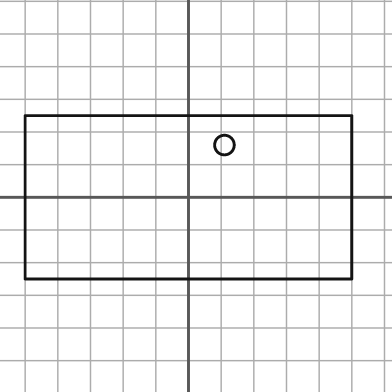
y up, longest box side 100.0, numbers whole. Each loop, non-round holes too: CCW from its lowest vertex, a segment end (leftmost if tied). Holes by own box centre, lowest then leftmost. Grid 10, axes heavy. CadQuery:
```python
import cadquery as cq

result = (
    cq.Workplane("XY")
    .moveTo(-50.0, -25.0)
    .lineTo(50.0, -25.0)
    .lineTo(50.0, 25.0)
    .lineTo(-50.0, 25.0)
    .close()
    .moveTo(11.0, 16.0)
    .circle(3.0)
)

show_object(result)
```